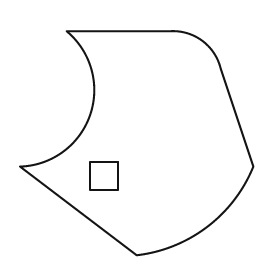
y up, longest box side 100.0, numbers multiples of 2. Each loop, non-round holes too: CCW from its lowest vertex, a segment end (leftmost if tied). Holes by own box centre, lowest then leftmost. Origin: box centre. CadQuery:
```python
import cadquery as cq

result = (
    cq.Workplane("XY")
    .moveTo(0.0, -48.0)
    .threePointArc((30.0, -36.0), (50.0, -10.0))
    .lineTo(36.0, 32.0)
    .threePointArc((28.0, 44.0), (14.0, 48.0))
    .lineTo(-30.0, 48.0)
    .threePointArc((-20.0, 12.0), (-50.0, -10.0))
    .close()
    .moveTo(-20.0, -20.0)
    .lineTo(-8.0, -20.0)
    .lineTo(-8.0, -8.0)
    .lineTo(-20.0, -8.0)
    .close()
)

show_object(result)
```